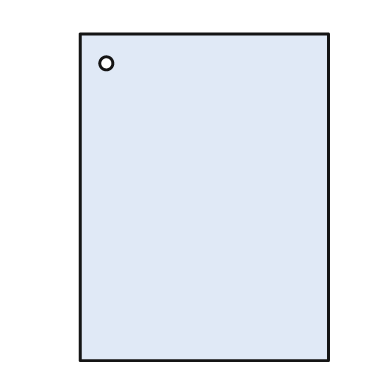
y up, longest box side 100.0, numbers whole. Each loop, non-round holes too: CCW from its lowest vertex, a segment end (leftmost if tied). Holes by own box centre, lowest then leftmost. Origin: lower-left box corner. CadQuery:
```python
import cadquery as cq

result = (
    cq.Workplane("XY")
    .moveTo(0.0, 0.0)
    .lineTo(76.0, 0.0)
    .lineTo(76.0, 100.0)
    .lineTo(0.0, 100.0)
    .close()
    .moveTo(8.0, 91.0)
    .circle(2.0)
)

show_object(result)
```